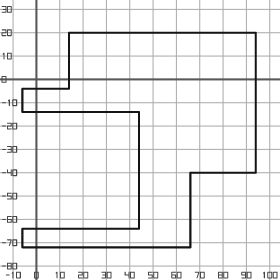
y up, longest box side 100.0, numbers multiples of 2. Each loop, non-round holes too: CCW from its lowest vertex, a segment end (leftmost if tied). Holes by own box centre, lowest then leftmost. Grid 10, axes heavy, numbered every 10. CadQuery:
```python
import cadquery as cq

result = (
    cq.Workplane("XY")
    .moveTo(-6.0, -72.0)
    .lineTo(66.0, -72.0)
    .lineTo(66.0, -40.0)
    .lineTo(94.0, -40.0)
    .lineTo(94.0, 20.0)
    .lineTo(14.0, 20.0)
    .lineTo(14.0, -4.0)
    .lineTo(-6.0, -4.0)
    .lineTo(-6.0, -14.0)
    .lineTo(44.0, -14.0)
    .lineTo(44.0, -64.0)
    .lineTo(-6.0, -64.0)
    .close()
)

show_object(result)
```